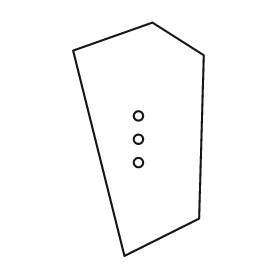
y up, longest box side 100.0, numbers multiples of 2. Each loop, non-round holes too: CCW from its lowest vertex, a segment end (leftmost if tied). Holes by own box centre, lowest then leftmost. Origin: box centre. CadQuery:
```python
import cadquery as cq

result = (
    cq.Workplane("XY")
    .moveTo(-6.0, -50.0)
    .lineTo(26.0, -34.0)
    .lineTo(28.0, 36.0)
    .lineTo(6.0, 50.0)
    .lineTo(-28.0, 38.0)
    .close()
    .moveTo(0.0, -10.0)
    .circle(2.0)
    .moveTo(0.0, 0.0)
    .circle(2.0)
    .moveTo(0.0, 10.0)
    .circle(2.0)
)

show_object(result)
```